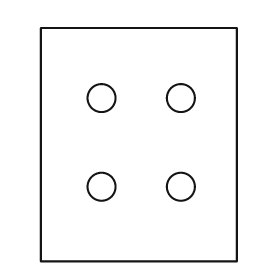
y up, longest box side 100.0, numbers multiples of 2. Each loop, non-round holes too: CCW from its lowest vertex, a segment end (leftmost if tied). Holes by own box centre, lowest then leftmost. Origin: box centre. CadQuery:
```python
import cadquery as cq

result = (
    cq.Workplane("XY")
    .moveTo(-42.0, -50.0)
    .lineTo(42.0, -50.0)
    .lineTo(42.0, 50.0)
    .lineTo(-42.0, 50.0)
    .close()
    .moveTo(-16.0, -18.0)
    .circle(6.0)
    .moveTo(18.0, -18.0)
    .circle(6.0)
    .moveTo(-16.0, 20.0)
    .circle(6.0)
    .moveTo(18.0, 20.0)
    .circle(6.0)
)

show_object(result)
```